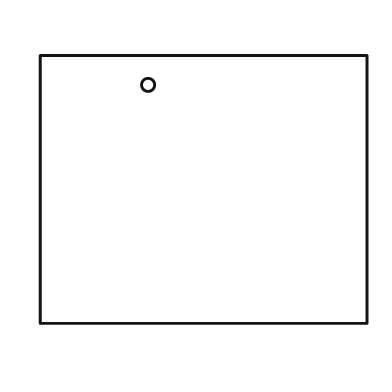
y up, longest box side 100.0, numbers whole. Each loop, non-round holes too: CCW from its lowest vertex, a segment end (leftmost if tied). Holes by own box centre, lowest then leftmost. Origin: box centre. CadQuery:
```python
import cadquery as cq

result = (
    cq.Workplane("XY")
    .moveTo(-50.0, -41.0)
    .lineTo(50.0, -41.0)
    .lineTo(50.0, 41.0)
    .lineTo(-50.0, 41.0)
    .close()
    .moveTo(-17.0, 32.0)
    .circle(2.0)
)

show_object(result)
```